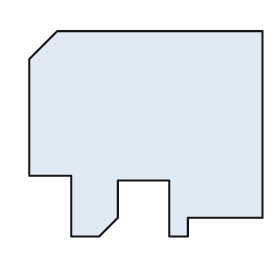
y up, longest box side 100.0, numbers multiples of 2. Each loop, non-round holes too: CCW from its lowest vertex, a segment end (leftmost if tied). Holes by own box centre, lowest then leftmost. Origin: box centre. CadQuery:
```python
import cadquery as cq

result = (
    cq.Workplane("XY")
    .moveTo(-32.0, -44.0)
    .lineTo(-20.0, -44.0)
    .lineTo(-12.0, -36.0)
    .lineTo(-12.0, -20.0)
    .lineTo(10.0, -20.0)
    .lineTo(10.0, -44.0)
    .lineTo(18.0, -44.0)
    .lineTo(18.0, -36.0)
    .lineTo(50.0, -36.0)
    .lineTo(50.0, 44.0)
    .lineTo(-38.0, 44.0)
    .lineTo(-50.0, 32.0)
    .lineTo(-50.0, -18.0)
    .lineTo(-32.0, -18.0)
    .close()
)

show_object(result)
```